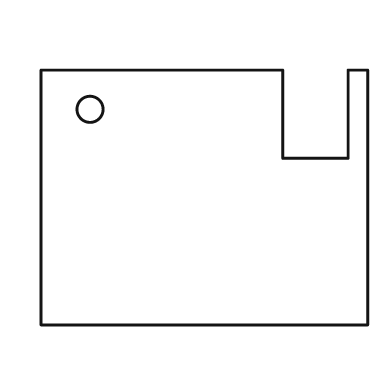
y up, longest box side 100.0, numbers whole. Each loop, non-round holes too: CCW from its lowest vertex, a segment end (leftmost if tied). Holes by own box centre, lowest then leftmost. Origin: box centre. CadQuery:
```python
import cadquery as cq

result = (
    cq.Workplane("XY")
    .moveTo(-50.0, -39.0)
    .lineTo(50.0, -39.0)
    .lineTo(50.0, 39.0)
    .lineTo(44.0, 39.0)
    .lineTo(44.0, 12.0)
    .lineTo(24.0, 12.0)
    .lineTo(24.0, 39.0)
    .lineTo(-50.0, 39.0)
    .close()
    .moveTo(-35.0, 27.0)
    .circle(4.0)
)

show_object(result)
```